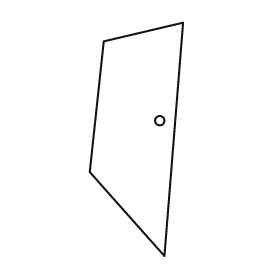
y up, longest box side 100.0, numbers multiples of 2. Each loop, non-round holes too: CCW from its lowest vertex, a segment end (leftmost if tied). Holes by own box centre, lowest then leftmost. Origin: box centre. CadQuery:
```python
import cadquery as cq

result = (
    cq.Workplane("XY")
    .moveTo(12.0, -50.0)
    .lineTo(20.0, 50.0)
    .lineTo(-14.0, 42.0)
    .lineTo(-20.0, -14.0)
    .close()
    .moveTo(10.0, 8.0)
    .circle(2.0)
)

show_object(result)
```